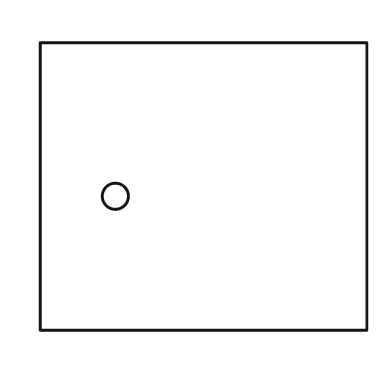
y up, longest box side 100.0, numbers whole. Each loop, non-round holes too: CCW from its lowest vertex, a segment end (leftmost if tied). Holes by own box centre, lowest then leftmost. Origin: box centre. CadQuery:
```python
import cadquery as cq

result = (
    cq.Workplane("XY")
    .moveTo(-50.0, -44.0)
    .lineTo(50.0, -44.0)
    .lineTo(50.0, 44.0)
    .lineTo(-50.0, 44.0)
    .close()
    .moveTo(-27.0, -3.0)
    .circle(4.0)
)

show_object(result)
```